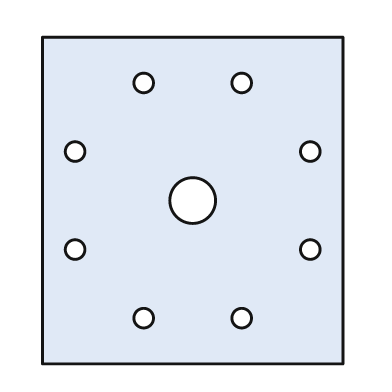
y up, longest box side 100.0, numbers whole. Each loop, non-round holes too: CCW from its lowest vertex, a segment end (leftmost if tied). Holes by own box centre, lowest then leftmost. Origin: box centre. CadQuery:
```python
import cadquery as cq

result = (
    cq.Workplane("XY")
    .moveTo(-46.0, -50.0)
    .lineTo(46.0, -50.0)
    .lineTo(46.0, 50.0)
    .lineTo(-46.0, 50.0)
    .close()
    .moveTo(-15.0, -36.0)
    .circle(3.0)
    .moveTo(15.0, -36.0)
    .circle(3.0)
    .moveTo(-36.0, -15.0)
    .circle(3.0)
    .moveTo(36.0, -15.0)
    .circle(3.0)
    .moveTo(0.0, 0.0)
    .circle(7.0)
    .moveTo(-36.0, 15.0)
    .circle(3.0)
    .moveTo(36.0, 15.0)
    .circle(3.0)
    .moveTo(-15.0, 36.0)
    .circle(3.0)
    .moveTo(15.0, 36.0)
    .circle(3.0)
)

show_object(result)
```